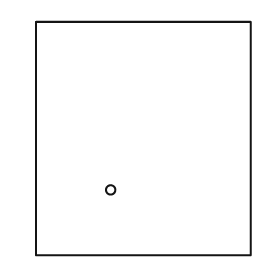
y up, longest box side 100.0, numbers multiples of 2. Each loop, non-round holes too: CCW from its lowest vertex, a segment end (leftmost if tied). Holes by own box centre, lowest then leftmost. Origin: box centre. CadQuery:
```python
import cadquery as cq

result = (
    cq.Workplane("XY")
    .moveTo(-46.0, -50.0)
    .lineTo(46.0, -50.0)
    .lineTo(46.0, 50.0)
    .lineTo(-46.0, 50.0)
    .close()
    .moveTo(-14.0, -22.0)
    .circle(2.0)
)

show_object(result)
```